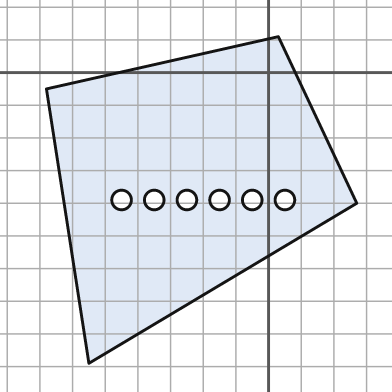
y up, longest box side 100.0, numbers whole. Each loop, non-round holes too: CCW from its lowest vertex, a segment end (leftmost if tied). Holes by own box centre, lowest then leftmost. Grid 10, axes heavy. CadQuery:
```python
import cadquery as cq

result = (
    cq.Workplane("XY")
    .moveTo(-55.0, -89.0)
    .lineTo(27.0, -40.0)
    .lineTo(3.0, 11.0)
    .lineTo(-68.0, -5.0)
    .close()
    .moveTo(-45.0, -39.0)
    .circle(3.0)
    .moveTo(-35.0, -39.0)
    .circle(3.0)
    .moveTo(-25.0, -39.0)
    .circle(3.0)
    .moveTo(-15.0, -39.0)
    .circle(3.0)
    .moveTo(-5.0, -39.0)
    .circle(3.0)
    .moveTo(5.0, -39.0)
    .circle(3.0)
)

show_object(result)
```